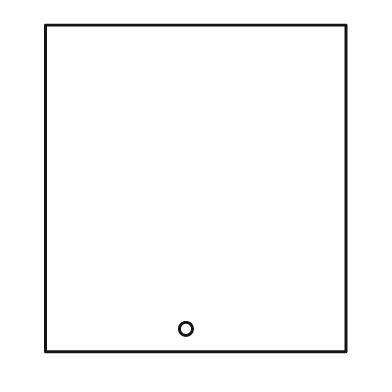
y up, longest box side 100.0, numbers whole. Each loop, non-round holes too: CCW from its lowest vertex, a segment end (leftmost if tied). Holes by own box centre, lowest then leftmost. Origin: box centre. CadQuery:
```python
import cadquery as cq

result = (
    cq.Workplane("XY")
    .moveTo(-46.0, -50.0)
    .lineTo(46.0, -50.0)
    .lineTo(46.0, 50.0)
    .lineTo(-46.0, 50.0)
    .close()
    .moveTo(-3.0, -43.0)
    .circle(2.0)
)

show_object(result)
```